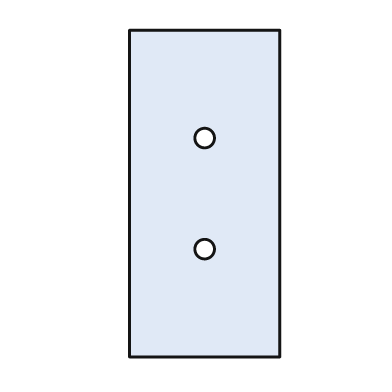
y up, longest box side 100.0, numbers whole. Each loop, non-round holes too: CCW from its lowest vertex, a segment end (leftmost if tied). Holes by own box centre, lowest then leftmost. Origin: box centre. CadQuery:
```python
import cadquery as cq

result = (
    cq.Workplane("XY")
    .moveTo(-23.0, -50.0)
    .lineTo(23.0, -50.0)
    .lineTo(23.0, 50.0)
    .lineTo(-23.0, 50.0)
    .close()
    .moveTo(0.0, -17.0)
    .circle(3.0)
    .moveTo(0.0, 17.0)
    .circle(3.0)
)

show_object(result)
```